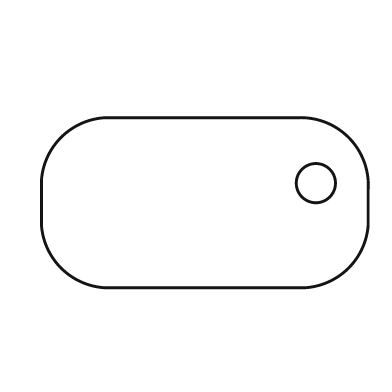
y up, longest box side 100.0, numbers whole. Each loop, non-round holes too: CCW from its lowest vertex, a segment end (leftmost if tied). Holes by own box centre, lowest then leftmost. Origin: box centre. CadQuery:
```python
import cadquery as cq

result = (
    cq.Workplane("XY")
    .moveTo(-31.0, -26.0)
    .lineTo(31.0, -26.0)
    .threePointArc((44.0, -20.0), (50.0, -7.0))
    .lineTo(50.0, 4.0)
    .threePointArc((44.0, 20.0), (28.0, 26.0))
    .lineTo(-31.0, 26.0)
    .threePointArc((-44.0, 20.0), (-50.0, 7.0))
    .lineTo(-50.0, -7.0)
    .threePointArc((-44.0, -20.0), (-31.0, -26.0))
    .close()
    .moveTo(34.0, 6.0)
    .circle(6.0)
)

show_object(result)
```